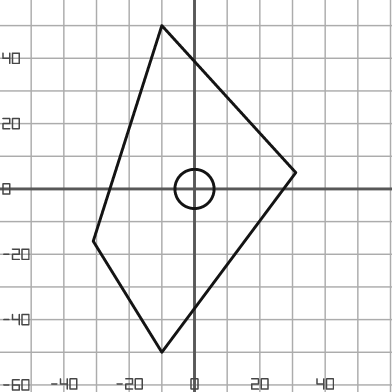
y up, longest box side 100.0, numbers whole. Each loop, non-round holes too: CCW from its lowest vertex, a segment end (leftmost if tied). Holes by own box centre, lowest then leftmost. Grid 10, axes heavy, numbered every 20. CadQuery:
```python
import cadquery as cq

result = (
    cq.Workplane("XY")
    .moveTo(-10.0, -50.0)
    .lineTo(31.0, 5.0)
    .lineTo(-10.0, 50.0)
    .lineTo(-31.0, -16.0)
    .close()
    .moveTo(0.0, 0.0)
    .circle(6.0)
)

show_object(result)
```